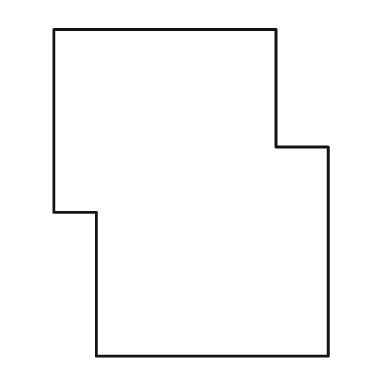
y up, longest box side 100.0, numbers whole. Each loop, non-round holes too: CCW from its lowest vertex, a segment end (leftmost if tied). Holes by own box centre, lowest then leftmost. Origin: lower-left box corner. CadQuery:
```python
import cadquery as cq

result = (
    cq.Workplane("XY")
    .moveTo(13.0, 0.0)
    .lineTo(84.0, 0.0)
    .lineTo(84.0, 64.0)
    .lineTo(68.0, 64.0)
    .lineTo(68.0, 100.0)
    .lineTo(0.0, 100.0)
    .lineTo(0.0, 44.0)
    .lineTo(13.0, 44.0)
    .close()
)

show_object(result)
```